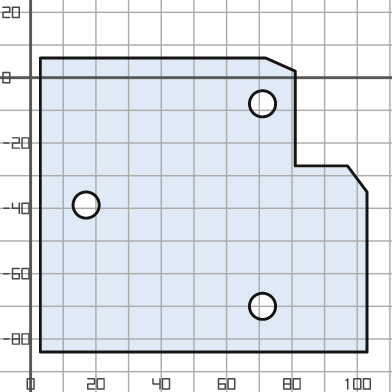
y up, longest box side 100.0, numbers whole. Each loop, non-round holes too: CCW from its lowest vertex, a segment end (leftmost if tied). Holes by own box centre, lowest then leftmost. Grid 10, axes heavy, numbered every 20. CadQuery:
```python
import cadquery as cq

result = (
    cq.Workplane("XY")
    .moveTo(3.0, -84.0)
    .lineTo(103.0, -84.0)
    .lineTo(103.0, -35.0)
    .lineTo(97.0, -27.0)
    .lineTo(81.0, -27.0)
    .lineTo(81.0, 2.0)
    .lineTo(72.0, 6.0)
    .lineTo(3.0, 6.0)
    .close()
    .moveTo(71.0, -70.0)
    .circle(4.0)
    .moveTo(17.0, -39.0)
    .circle(4.0)
    .moveTo(71.0, -8.0)
    .circle(4.0)
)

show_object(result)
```